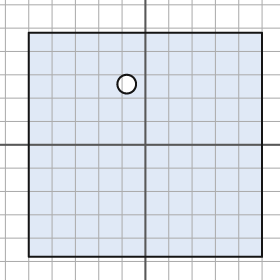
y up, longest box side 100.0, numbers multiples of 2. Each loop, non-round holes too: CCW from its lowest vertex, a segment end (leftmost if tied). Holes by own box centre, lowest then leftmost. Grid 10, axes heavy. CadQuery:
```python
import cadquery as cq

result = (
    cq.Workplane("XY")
    .moveTo(-50.0, -48.0)
    .lineTo(50.0, -48.0)
    .lineTo(50.0, 48.0)
    .lineTo(-50.0, 48.0)
    .close()
    .moveTo(-8.0, 26.0)
    .circle(4.0)
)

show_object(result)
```